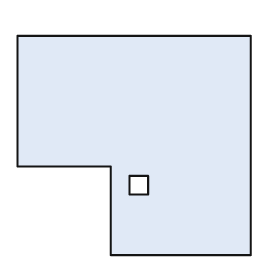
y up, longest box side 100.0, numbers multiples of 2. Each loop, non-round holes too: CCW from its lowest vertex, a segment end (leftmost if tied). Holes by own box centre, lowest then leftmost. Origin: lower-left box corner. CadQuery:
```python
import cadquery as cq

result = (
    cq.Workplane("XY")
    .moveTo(40.0, 0.0)
    .lineTo(100.0, 0.0)
    .lineTo(100.0, 94.0)
    .lineTo(0.0, 94.0)
    .lineTo(0.0, 38.0)
    .lineTo(40.0, 38.0)
    .close()
    .moveTo(48.0, 26.0)
    .lineTo(56.0, 26.0)
    .lineTo(56.0, 34.0)
    .lineTo(48.0, 34.0)
    .close()
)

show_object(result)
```